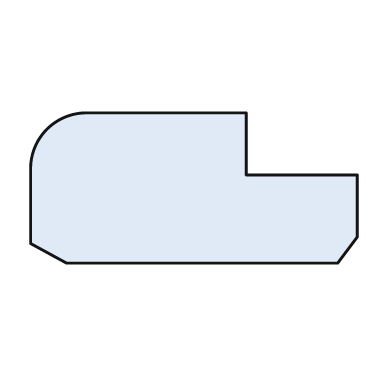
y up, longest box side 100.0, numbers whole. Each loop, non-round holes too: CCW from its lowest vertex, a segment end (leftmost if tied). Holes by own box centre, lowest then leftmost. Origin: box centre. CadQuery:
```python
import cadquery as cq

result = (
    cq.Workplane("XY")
    .moveTo(-39.0, -23.0)
    .lineTo(44.0, -23.0)
    .lineTo(50.0, -15.0)
    .lineTo(50.0, 4.0)
    .lineTo(16.0, 4.0)
    .lineTo(16.0, 23.0)
    .lineTo(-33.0, 23.0)
    .threePointArc((-45.0, 18.0), (-50.0, 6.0))
    .lineTo(-50.0, -17.0)
    .close()
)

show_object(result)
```